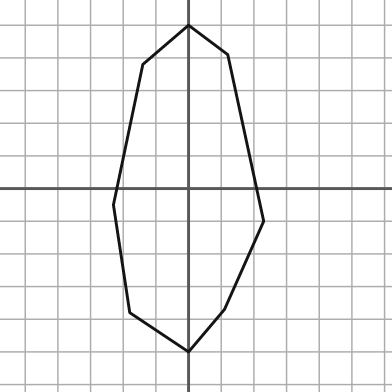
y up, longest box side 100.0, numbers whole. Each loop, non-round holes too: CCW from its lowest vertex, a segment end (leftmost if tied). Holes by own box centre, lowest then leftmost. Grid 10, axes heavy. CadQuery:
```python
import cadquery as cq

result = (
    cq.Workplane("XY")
    .moveTo(0.0, -50.0)
    .lineTo(11.0, -37.0)
    .lineTo(23.0, -10.0)
    .lineTo(12.0, 41.0)
    .lineTo(0.0, 50.0)
    .lineTo(-14.0, 38.0)
    .lineTo(-23.0, -5.0)
    .lineTo(-18.0, -38.0)
    .close()
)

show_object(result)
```